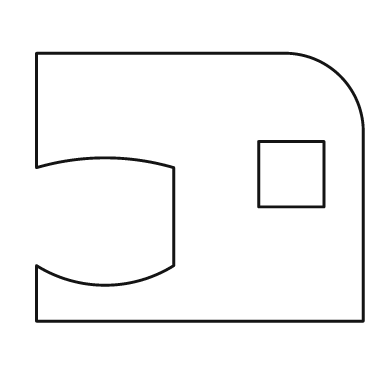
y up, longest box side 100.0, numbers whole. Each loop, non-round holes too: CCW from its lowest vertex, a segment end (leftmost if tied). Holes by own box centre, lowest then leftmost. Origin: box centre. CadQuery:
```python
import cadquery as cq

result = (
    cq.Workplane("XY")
    .moveTo(-50.0, -41.0)
    .lineTo(50.0, -41.0)
    .lineTo(50.0, 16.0)
    .threePointArc((43.0, 34.0), (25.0, 41.0))
    .lineTo(-50.0, 41.0)
    .lineTo(-50.0, 6.0)
    .threePointArc((-29.0, 9.0), (-8.0, 6.0))
    .lineTo(-8.0, -24.0)
    .threePointArc((-29.0, -30.0), (-50.0, -24.0))
    .close()
    .moveTo(18.0, -6.0)
    .lineTo(38.0, -6.0)
    .lineTo(38.0, 14.0)
    .lineTo(18.0, 14.0)
    .close()
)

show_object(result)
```